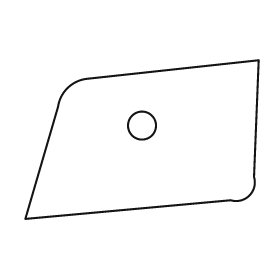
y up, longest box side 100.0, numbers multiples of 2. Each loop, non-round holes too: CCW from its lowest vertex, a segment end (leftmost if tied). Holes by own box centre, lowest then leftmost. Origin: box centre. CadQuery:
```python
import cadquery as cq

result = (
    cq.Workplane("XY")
    .moveTo(-50.0, -34.0)
    .lineTo(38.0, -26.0)
    .threePointArc((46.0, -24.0), (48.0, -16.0))
    .lineTo(50.0, 34.0)
    .lineTo(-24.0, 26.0)
    .threePointArc((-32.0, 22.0), (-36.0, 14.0))
    .close()
    .moveTo(0.0, 6.0)
    .circle(6.0)
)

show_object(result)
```